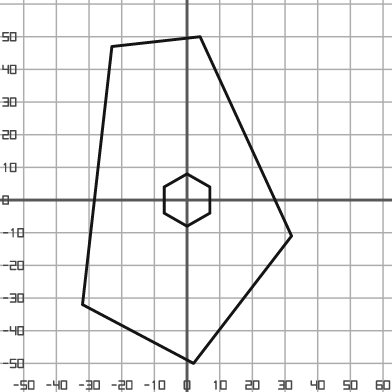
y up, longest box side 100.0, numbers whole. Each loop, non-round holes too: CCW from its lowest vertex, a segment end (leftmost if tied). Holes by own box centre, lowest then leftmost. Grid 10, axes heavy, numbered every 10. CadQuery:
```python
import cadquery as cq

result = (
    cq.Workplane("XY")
    .moveTo(2.0, -50.0)
    .lineTo(32.0, -11.0)
    .lineTo(4.0, 50.0)
    .lineTo(-23.0, 47.0)
    .lineTo(-32.0, -32.0)
    .close()
    .moveTo(0.0, -8.0)
    .lineTo(7.0, -4.0)
    .lineTo(7.0, 4.0)
    .lineTo(0.0, 8.0)
    .lineTo(-7.0, 4.0)
    .lineTo(-7.0, -4.0)
    .close()
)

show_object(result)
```